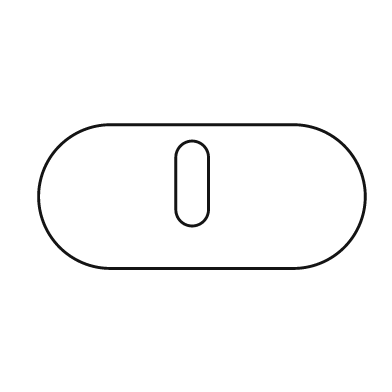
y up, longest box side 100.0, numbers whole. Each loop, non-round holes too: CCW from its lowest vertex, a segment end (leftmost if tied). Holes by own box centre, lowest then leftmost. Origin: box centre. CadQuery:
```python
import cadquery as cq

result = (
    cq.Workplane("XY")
    .moveTo(-28.0, -22.0)
    .lineTo(28.0, -22.0)
    .threePointArc((50.0, 0.0), (28.0, 22.0))
    .lineTo(-28.0, 22.0)
    .threePointArc((-50.0, 0.0), (-28.0, -22.0))
    .close()
    .moveTo(-8.0, -4.0)
    .threePointArc((-3.0, -9.0), (2.0, -4.0))
    .lineTo(2.0, 12.0)
    .threePointArc((-3.0, 17.0), (-8.0, 12.0))
    .close()
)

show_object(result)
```